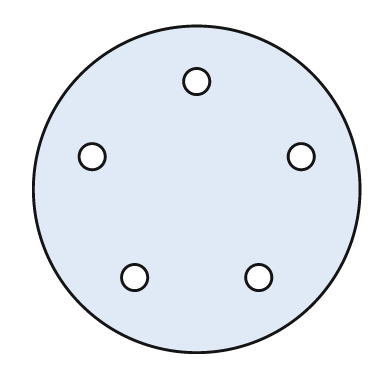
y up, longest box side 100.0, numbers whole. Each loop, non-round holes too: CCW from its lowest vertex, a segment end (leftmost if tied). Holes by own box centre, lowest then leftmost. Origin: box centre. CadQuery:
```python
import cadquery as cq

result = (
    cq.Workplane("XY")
    .moveTo(0.0, 0.0)
    .circle(50.0)
    .moveTo(-19.0, -27.0)
    .circle(4.0)
    .moveTo(19.0, -27.0)
    .circle(4.0)
    .moveTo(-32.0, 10.0)
    .circle(4.0)
    .moveTo(32.0, 10.0)
    .circle(4.0)
    .moveTo(0.0, 33.0)
    .circle(4.0)
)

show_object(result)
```